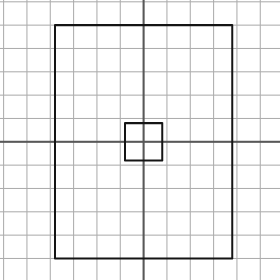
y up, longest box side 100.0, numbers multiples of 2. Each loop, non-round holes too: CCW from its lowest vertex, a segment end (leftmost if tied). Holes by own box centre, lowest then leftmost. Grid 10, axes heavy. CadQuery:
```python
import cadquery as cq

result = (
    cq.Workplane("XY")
    .moveTo(-38.0, -50.0)
    .lineTo(38.0, -50.0)
    .lineTo(38.0, 50.0)
    .lineTo(-38.0, 50.0)
    .close()
    .moveTo(-8.0, -8.0)
    .lineTo(8.0, -8.0)
    .lineTo(8.0, 8.0)
    .lineTo(-8.0, 8.0)
    .close()
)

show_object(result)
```